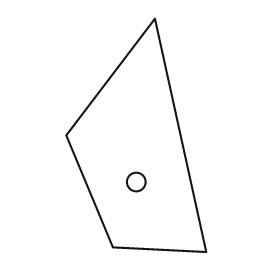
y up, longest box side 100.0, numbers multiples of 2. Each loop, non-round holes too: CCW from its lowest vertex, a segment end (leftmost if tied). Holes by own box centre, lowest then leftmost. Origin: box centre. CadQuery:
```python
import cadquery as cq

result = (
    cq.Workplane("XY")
    .moveTo(30.0, -50.0)
    .lineTo(8.0, 50.0)
    .lineTo(-30.0, 0.0)
    .lineTo(-10.0, -48.0)
    .close()
    .moveTo(0.0, -20.0)
    .circle(4.0)
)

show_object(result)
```